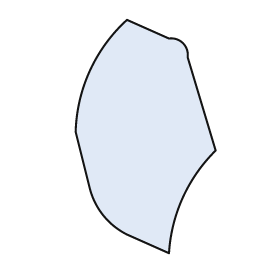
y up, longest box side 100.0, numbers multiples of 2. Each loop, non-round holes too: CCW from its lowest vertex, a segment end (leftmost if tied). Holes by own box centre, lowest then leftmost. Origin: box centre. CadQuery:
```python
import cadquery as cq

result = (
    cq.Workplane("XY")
    .moveTo(10.0, -50.0)
    .threePointArc((16.0, -26.0), (30.0, -6.0))
    .lineTo(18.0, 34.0)
    .threePointArc((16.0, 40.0), (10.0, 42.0))
    .lineTo(-8.0, 50.0)
    .threePointArc((-24.0, 28.0), (-30.0, 2.0))
    .lineTo(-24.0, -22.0)
    .threePointArc((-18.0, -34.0), (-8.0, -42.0))
    .close()
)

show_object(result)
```